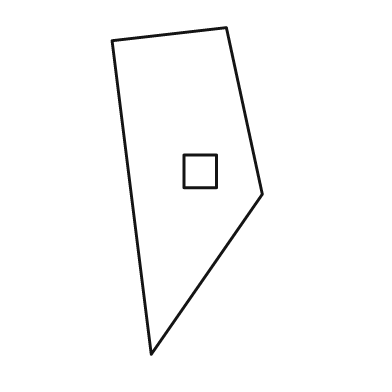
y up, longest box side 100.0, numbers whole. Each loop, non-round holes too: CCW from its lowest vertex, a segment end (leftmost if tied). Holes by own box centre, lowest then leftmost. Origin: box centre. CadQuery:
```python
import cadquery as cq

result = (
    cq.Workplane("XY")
    .moveTo(-11.0, -50.0)
    .lineTo(23.0, -1.0)
    .lineTo(12.0, 50.0)
    .lineTo(-23.0, 46.0)
    .close()
    .moveTo(-1.0, 1.0)
    .lineTo(9.0, 1.0)
    .lineTo(9.0, 11.0)
    .lineTo(-1.0, 11.0)
    .close()
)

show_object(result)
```